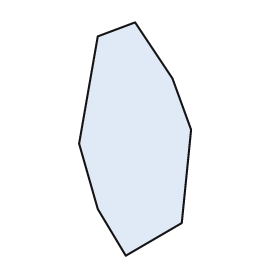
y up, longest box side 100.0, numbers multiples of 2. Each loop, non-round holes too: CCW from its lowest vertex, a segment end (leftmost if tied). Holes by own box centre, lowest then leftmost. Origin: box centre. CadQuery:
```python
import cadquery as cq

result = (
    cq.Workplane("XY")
    .moveTo(-4.0, -50.0)
    .lineTo(20.0, -36.0)
    .lineTo(24.0, 4.0)
    .lineTo(16.0, 26.0)
    .lineTo(0.0, 50.0)
    .lineTo(-16.0, 44.0)
    .lineTo(-24.0, -2.0)
    .lineTo(-16.0, -30.0)
    .close()
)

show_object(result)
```